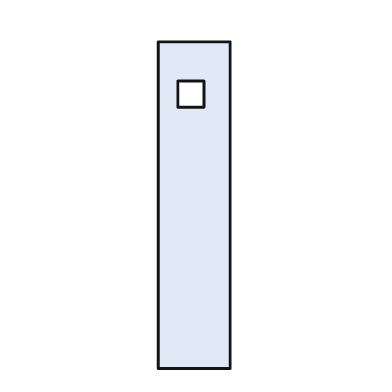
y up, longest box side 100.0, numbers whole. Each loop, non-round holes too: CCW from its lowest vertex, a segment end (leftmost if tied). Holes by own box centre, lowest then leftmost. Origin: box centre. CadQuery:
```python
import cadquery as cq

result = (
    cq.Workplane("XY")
    .moveTo(-11.0, -50.0)
    .lineTo(11.0, -50.0)
    .lineTo(11.0, 50.0)
    .lineTo(-11.0, 50.0)
    .close()
    .moveTo(-5.0, 30.0)
    .lineTo(3.0, 30.0)
    .lineTo(3.0, 38.0)
    .lineTo(-5.0, 38.0)
    .close()
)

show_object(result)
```